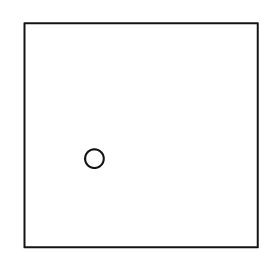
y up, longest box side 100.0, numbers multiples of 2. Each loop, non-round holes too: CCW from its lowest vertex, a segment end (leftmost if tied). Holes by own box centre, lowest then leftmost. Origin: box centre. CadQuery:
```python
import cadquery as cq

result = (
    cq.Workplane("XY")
    .moveTo(-50.0, -48.0)
    .lineTo(50.0, -48.0)
    .lineTo(50.0, 48.0)
    .lineTo(-50.0, 48.0)
    .close()
    .moveTo(-20.0, -10.0)
    .circle(4.0)
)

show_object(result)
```